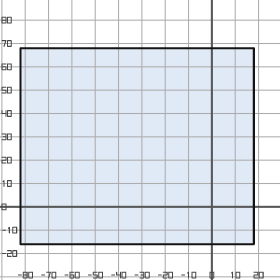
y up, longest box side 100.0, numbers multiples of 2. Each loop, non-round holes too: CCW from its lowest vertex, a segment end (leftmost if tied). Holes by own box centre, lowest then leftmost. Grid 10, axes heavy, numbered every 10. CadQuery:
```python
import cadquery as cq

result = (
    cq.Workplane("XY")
    .moveTo(-82.0, -16.0)
    .lineTo(18.0, -16.0)
    .lineTo(18.0, 68.0)
    .lineTo(-82.0, 68.0)
    .close()
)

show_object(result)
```